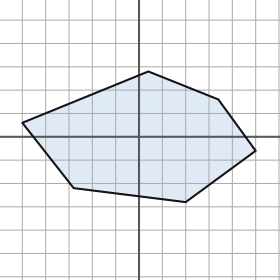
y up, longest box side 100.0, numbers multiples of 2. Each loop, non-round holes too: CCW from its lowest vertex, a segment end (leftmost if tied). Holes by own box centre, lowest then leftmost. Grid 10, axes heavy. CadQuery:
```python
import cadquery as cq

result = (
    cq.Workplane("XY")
    .moveTo(20.0, -28.0)
    .lineTo(50.0, -6.0)
    .lineTo(34.0, 16.0)
    .lineTo(4.0, 28.0)
    .lineTo(-50.0, 6.0)
    .lineTo(-28.0, -22.0)
    .close()
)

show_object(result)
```